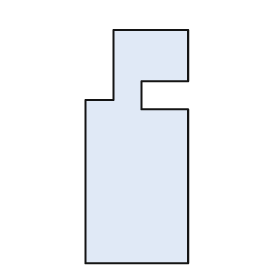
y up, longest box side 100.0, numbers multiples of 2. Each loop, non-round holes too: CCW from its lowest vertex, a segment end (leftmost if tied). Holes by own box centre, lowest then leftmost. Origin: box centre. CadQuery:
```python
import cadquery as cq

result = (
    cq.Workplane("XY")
    .moveTo(-22.0, -50.0)
    .lineTo(22.0, -50.0)
    .lineTo(22.0, 16.0)
    .lineTo(2.0, 16.0)
    .lineTo(2.0, 28.0)
    .lineTo(22.0, 28.0)
    .lineTo(22.0, 50.0)
    .lineTo(-10.0, 50.0)
    .lineTo(-10.0, 20.0)
    .lineTo(-22.0, 20.0)
    .close()
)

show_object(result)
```